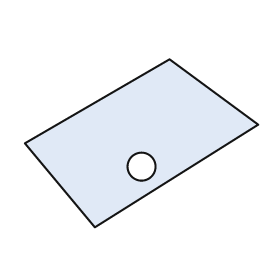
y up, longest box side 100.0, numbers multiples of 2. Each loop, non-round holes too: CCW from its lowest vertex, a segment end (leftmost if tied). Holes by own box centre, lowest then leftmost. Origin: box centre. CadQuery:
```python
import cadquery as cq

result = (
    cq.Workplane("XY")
    .moveTo(-20.0, -36.0)
    .lineTo(50.0, 8.0)
    .lineTo(12.0, 36.0)
    .lineTo(-50.0, 0.0)
    .close()
    .moveTo(0.0, -10.0)
    .circle(6.0)
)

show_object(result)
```